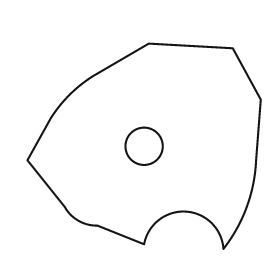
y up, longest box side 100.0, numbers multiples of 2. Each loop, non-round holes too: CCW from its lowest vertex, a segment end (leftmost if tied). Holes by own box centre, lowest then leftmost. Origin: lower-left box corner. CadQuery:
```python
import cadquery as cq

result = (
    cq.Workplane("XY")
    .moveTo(84.0, 0.0)
    .threePointArc((94.0, 18.0), (98.0, 38.0))
    .lineTo(100.0, 64.0)
    .lineTo(88.0, 86.0)
    .lineTo(52.0, 88.0)
    .lineTo(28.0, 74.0)
    .threePointArc((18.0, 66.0), (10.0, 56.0))
    .lineTo(0.0, 38.0)
    .lineTo(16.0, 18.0)
    .threePointArc((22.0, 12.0), (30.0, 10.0))
    .lineTo(50.0, 2.0)
    .threePointArc((68.0, 16.0), (84.0, 0.0))
    .close()
    .moveTo(50.0, 44.0)
    .circle(8.0)
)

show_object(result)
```